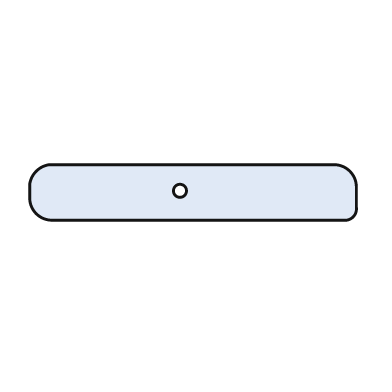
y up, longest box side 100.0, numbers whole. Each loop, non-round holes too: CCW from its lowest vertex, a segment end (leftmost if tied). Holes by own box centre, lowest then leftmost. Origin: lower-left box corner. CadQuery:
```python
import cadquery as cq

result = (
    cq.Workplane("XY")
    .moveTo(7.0, 0.0)
    .lineTo(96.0, 0.0)
    .threePointArc((99.0, 1.0), (100.0, 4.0))
    .lineTo(100.0, 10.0)
    .threePointArc((98.0, 15.0), (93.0, 17.0))
    .lineTo(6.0, 17.0)
    .threePointArc((2.0, 15.0), (0.0, 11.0))
    .lineTo(0.0, 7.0)
    .threePointArc((2.0, 2.0), (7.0, 0.0))
    .close()
    .moveTo(46.0, 9.0)
    .circle(2.0)
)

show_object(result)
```